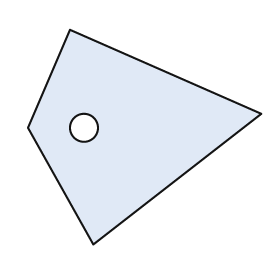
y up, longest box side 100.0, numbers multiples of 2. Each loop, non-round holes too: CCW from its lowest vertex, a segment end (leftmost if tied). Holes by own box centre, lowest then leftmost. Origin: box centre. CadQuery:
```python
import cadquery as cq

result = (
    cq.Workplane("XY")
    .moveTo(-22.0, -46.0)
    .lineTo(50.0, 10.0)
    .lineTo(-32.0, 46.0)
    .lineTo(-50.0, 4.0)
    .close()
    .moveTo(-26.0, 4.0)
    .circle(6.0)
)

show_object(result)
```